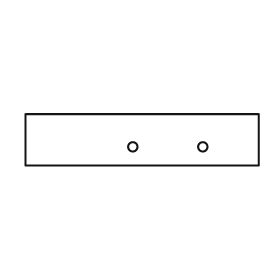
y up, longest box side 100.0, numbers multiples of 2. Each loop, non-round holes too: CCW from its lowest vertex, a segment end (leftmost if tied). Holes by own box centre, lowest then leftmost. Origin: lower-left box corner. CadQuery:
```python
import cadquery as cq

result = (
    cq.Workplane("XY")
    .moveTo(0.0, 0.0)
    .lineTo(100.0, 0.0)
    .lineTo(100.0, 22.0)
    .lineTo(0.0, 22.0)
    .close()
    .moveTo(46.0, 8.0)
    .circle(2.0)
    .moveTo(76.0, 8.0)
    .circle(2.0)
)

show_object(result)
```